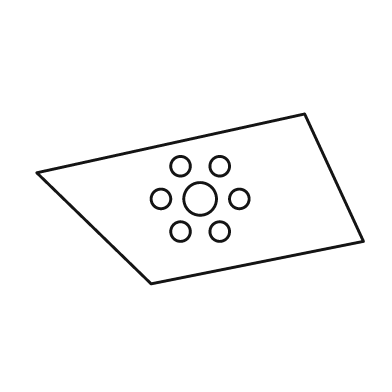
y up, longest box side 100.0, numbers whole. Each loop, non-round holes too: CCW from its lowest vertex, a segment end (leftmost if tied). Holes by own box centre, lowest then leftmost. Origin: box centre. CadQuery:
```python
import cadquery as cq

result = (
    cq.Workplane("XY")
    .moveTo(-15.0, -26.0)
    .lineTo(50.0, -13.0)
    .lineTo(32.0, 26.0)
    .lineTo(-50.0, 8.0)
    .close()
    .moveTo(-6.0, -10.0)
    .circle(3.0)
    .moveTo(6.0, -10.0)
    .circle(3.0)
    .moveTo(-12.0, 0.0)
    .circle(3.0)
    .moveTo(0.0, 0.0)
    .circle(5.0)
    .moveTo(12.0, 0.0)
    .circle(3.0)
    .moveTo(-6.0, 10.0)
    .circle(3.0)
    .moveTo(6.0, 10.0)
    .circle(3.0)
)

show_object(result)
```